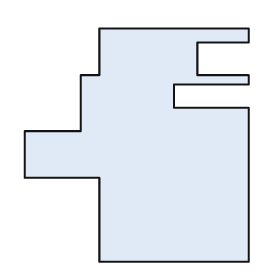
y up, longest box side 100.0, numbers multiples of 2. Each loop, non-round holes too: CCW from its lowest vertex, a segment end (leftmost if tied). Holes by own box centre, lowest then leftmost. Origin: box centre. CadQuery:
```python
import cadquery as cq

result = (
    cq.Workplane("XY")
    .moveTo(-16.0, -50.0)
    .lineTo(48.0, -50.0)
    .lineTo(48.0, 16.0)
    .lineTo(16.0, 16.0)
    .lineTo(16.0, 26.0)
    .lineTo(48.0, 26.0)
    .lineTo(48.0, 30.0)
    .lineTo(26.0, 30.0)
    .lineTo(26.0, 44.0)
    .lineTo(48.0, 44.0)
    .lineTo(48.0, 50.0)
    .lineTo(-16.0, 50.0)
    .lineTo(-16.0, 30.0)
    .lineTo(-24.0, 30.0)
    .lineTo(-24.0, 6.0)
    .lineTo(-48.0, 6.0)
    .lineTo(-48.0, -14.0)
    .lineTo(-16.0, -14.0)
    .close()
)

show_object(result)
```